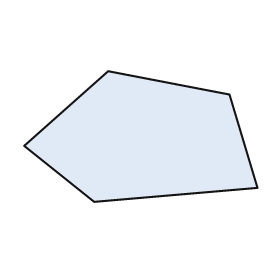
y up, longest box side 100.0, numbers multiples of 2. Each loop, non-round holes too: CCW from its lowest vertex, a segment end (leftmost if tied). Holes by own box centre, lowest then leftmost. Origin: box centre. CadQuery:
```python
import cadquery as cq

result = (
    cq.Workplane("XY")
    .moveTo(-20.0, -28.0)
    .lineTo(50.0, -22.0)
    .lineTo(38.0, 18.0)
    .lineTo(-14.0, 28.0)
    .lineTo(-50.0, -4.0)
    .close()
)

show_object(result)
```